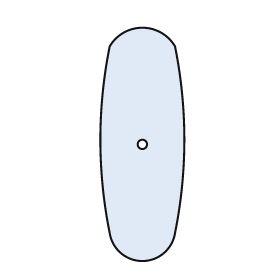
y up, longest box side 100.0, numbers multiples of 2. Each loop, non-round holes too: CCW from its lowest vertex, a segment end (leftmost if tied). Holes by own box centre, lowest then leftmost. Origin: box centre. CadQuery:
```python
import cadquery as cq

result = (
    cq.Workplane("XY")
    .moveTo(-14.0, -38.0)
    .threePointArc((0.0, -50.0), (14.0, -38.0))
    .threePointArc((18.0, 2.0), (14.0, 42.0))
    .threePointArc((0.0, 50.0), (-14.0, 42.0))
    .threePointArc((-18.0, 2.0), (-14.0, -38.0))
    .close()
    .moveTo(0.0, 0.0)
    .circle(2.0)
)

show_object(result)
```